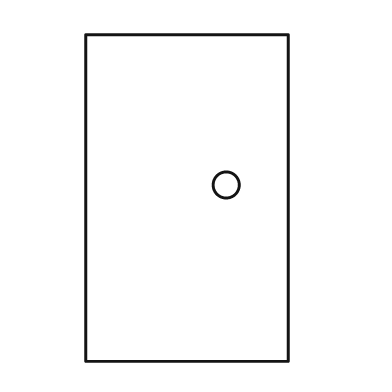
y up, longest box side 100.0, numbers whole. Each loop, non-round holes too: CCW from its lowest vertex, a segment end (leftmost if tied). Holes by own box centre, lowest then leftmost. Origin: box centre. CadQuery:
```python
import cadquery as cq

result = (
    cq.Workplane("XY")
    .moveTo(-31.0, -50.0)
    .lineTo(31.0, -50.0)
    .lineTo(31.0, 50.0)
    .lineTo(-31.0, 50.0)
    .close()
    .moveTo(12.0, 4.0)
    .circle(4.0)
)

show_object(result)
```